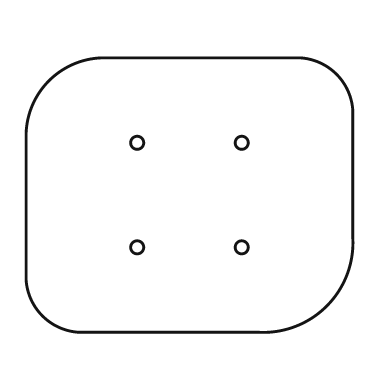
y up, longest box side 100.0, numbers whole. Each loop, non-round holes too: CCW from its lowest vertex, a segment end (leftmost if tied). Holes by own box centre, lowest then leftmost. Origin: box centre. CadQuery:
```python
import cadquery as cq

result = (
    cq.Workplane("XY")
    .moveTo(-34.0, -42.0)
    .lineTo(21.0, -42.0)
    .threePointArc((42.0, -34.0), (50.0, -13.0))
    .lineTo(50.0, 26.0)
    .threePointArc((45.0, 37.0), (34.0, 42.0))
    .lineTo(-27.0, 42.0)
    .threePointArc((-43.0, 35.0), (-50.0, 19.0))
    .lineTo(-50.0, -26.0)
    .threePointArc((-45.0, -37.0), (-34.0, -42.0))
    .close()
    .moveTo(-16.0, -16.0)
    .circle(2.0)
    .moveTo(16.0, -16.0)
    .circle(2.0)
    .moveTo(-16.0, 16.0)
    .circle(2.0)
    .moveTo(16.0, 16.0)
    .circle(2.0)
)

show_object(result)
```